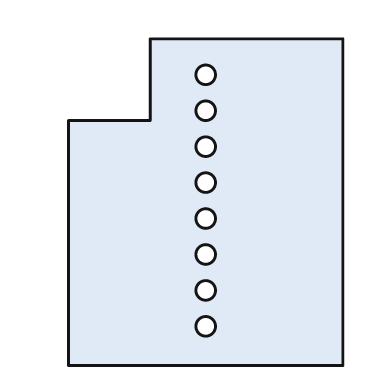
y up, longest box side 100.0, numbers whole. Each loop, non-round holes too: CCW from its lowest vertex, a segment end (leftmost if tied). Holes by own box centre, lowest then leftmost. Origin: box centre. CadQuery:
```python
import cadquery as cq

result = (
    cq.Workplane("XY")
    .moveTo(-42.0, -50.0)
    .lineTo(42.0, -50.0)
    .lineTo(42.0, 50.0)
    .lineTo(-17.0, 50.0)
    .lineTo(-17.0, 25.0)
    .lineTo(-42.0, 25.0)
    .close()
    .moveTo(0.0, -38.0)
    .circle(3.0)
    .moveTo(0.0, -27.0)
    .circle(3.0)
    .moveTo(0.0, -16.0)
    .circle(3.0)
    .moveTo(0.0, -5.0)
    .circle(3.0)
    .moveTo(0.0, 6.0)
    .circle(3.0)
    .moveTo(0.0, 17.0)
    .circle(3.0)
    .moveTo(0.0, 28.0)
    .circle(3.0)
    .moveTo(0.0, 39.0)
    .circle(3.0)
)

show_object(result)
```